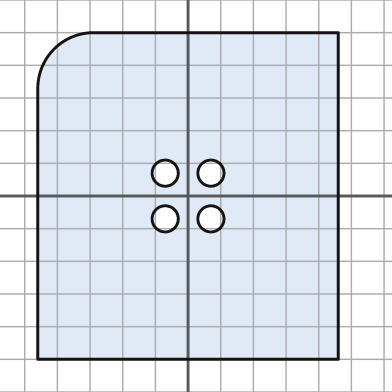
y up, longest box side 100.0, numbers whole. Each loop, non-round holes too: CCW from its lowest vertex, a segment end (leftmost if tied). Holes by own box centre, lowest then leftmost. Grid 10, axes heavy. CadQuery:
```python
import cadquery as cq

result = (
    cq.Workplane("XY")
    .moveTo(-46.0, -50.0)
    .lineTo(46.0, -50.0)
    .lineTo(46.0, 50.0)
    .lineTo(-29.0, 50.0)
    .threePointArc((-41.0, 45.0), (-46.0, 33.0))
    .close()
    .moveTo(-7.0, -7.0)
    .circle(4.0)
    .moveTo(7.0, -7.0)
    .circle(4.0)
    .moveTo(-7.0, 7.0)
    .circle(4.0)
    .moveTo(7.0, 7.0)
    .circle(4.0)
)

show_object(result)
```